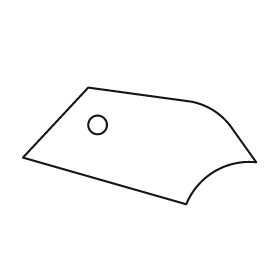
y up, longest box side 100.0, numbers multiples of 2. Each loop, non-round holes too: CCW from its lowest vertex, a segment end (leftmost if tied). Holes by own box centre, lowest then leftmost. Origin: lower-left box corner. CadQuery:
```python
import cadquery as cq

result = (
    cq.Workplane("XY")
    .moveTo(70.0, 0.0)
    .threePointArc((82.0, 14.0), (100.0, 18.0))
    .lineTo(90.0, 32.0)
    .threePointArc((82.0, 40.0), (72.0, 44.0))
    .lineTo(28.0, 50.0)
    .lineTo(0.0, 20.0)
    .close()
    .moveTo(32.0, 34.0)
    .circle(4.0)
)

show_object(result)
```